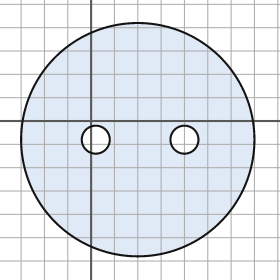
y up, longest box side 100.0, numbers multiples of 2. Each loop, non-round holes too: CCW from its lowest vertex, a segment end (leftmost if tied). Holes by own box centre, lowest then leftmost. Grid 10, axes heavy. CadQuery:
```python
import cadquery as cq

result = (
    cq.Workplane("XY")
    .moveTo(20.0, -8.0)
    .circle(50.0)
    .moveTo(2.0, -8.0)
    .circle(6.0)
    .moveTo(40.0, -8.0)
    .circle(6.0)
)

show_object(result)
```